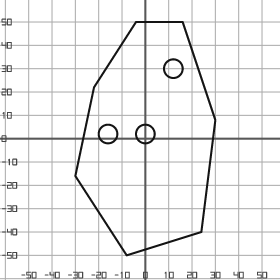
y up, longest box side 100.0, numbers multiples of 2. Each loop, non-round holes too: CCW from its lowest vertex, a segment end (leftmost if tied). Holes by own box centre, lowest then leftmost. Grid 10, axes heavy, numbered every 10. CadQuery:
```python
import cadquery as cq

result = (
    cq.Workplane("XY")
    .moveTo(-8.0, -50.0)
    .lineTo(24.0, -40.0)
    .lineTo(30.0, 8.0)
    .lineTo(16.0, 50.0)
    .lineTo(-4.0, 50.0)
    .lineTo(-22.0, 22.0)
    .lineTo(-30.0, -16.0)
    .close()
    .moveTo(-16.0, 2.0)
    .circle(4.0)
    .moveTo(0.0, 2.0)
    .circle(4.0)
    .moveTo(12.0, 30.0)
    .circle(4.0)
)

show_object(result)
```